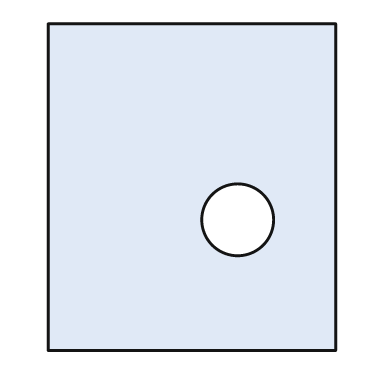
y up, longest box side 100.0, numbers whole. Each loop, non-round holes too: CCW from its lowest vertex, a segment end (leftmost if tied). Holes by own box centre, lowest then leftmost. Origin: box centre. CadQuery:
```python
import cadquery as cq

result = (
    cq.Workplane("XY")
    .moveTo(-44.0, -50.0)
    .lineTo(44.0, -50.0)
    .lineTo(44.0, 50.0)
    .lineTo(-44.0, 50.0)
    .close()
    .moveTo(14.0, -10.0)
    .circle(11.0)
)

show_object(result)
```